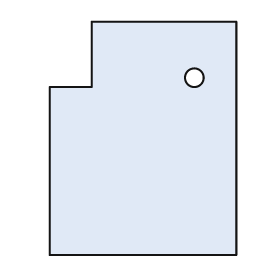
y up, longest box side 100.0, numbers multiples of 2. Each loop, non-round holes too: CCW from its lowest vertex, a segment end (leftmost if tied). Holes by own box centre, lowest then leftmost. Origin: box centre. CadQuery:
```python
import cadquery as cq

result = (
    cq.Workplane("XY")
    .moveTo(-40.0, -50.0)
    .lineTo(40.0, -50.0)
    .lineTo(40.0, 50.0)
    .lineTo(-22.0, 50.0)
    .lineTo(-22.0, 22.0)
    .lineTo(-40.0, 22.0)
    .close()
    .moveTo(22.0, 26.0)
    .circle(4.0)
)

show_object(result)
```